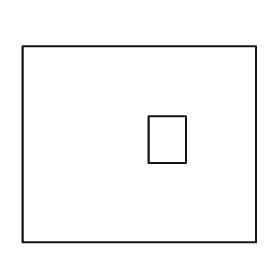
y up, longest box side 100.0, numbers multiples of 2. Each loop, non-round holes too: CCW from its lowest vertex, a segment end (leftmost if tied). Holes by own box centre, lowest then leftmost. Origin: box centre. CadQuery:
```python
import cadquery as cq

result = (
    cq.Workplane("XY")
    .moveTo(-50.0, -42.0)
    .lineTo(50.0, -42.0)
    .lineTo(50.0, 42.0)
    .lineTo(-50.0, 42.0)
    .close()
    .moveTo(4.0, -8.0)
    .lineTo(20.0, -8.0)
    .lineTo(20.0, 12.0)
    .lineTo(4.0, 12.0)
    .close()
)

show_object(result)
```